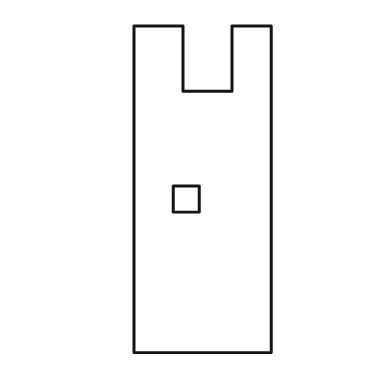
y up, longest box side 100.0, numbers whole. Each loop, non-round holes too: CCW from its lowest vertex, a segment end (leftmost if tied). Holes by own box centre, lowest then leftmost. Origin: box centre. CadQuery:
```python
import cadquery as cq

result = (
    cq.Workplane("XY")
    .moveTo(-21.0, -50.0)
    .lineTo(21.0, -50.0)
    .lineTo(21.0, 50.0)
    .lineTo(9.0, 50.0)
    .lineTo(9.0, 30.0)
    .lineTo(-6.0, 30.0)
    .lineTo(-6.0, 50.0)
    .lineTo(-21.0, 50.0)
    .close()
    .moveTo(-9.0, -7.0)
    .lineTo(-1.0, -7.0)
    .lineTo(-1.0, 1.0)
    .lineTo(-9.0, 1.0)
    .close()
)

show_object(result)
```